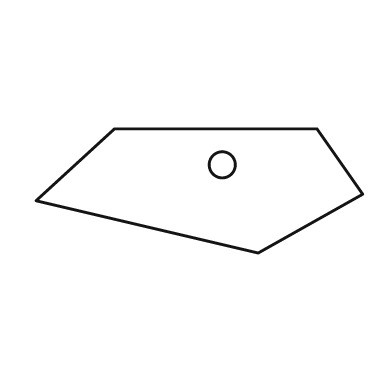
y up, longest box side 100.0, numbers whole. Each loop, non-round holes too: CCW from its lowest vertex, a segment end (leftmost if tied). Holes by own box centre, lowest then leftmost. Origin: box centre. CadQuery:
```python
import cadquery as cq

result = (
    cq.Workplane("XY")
    .moveTo(18.0, -19.0)
    .lineTo(50.0, -1.0)
    .lineTo(36.0, 19.0)
    .lineTo(-26.0, 19.0)
    .lineTo(-50.0, -3.0)
    .close()
    .moveTo(7.0, 8.0)
    .circle(4.0)
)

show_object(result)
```